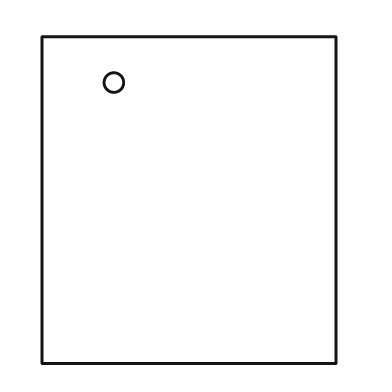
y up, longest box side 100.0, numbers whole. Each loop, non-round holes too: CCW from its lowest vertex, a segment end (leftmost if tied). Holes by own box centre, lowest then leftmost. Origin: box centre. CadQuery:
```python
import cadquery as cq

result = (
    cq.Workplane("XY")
    .moveTo(-45.0, -50.0)
    .lineTo(45.0, -50.0)
    .lineTo(45.0, 50.0)
    .lineTo(-45.0, 50.0)
    .close()
    .moveTo(-23.0, 36.0)
    .circle(3.0)
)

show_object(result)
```